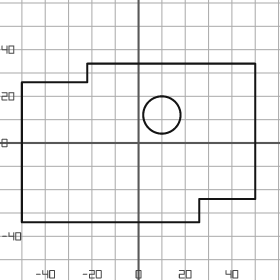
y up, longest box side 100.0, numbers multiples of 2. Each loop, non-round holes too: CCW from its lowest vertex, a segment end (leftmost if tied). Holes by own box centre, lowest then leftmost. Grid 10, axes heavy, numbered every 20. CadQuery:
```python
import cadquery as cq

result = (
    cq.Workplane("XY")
    .moveTo(-50.0, -34.0)
    .lineTo(26.0, -34.0)
    .lineTo(26.0, -24.0)
    .lineTo(50.0, -24.0)
    .lineTo(50.0, 34.0)
    .lineTo(-22.0, 34.0)
    .lineTo(-22.0, 26.0)
    .lineTo(-50.0, 26.0)
    .close()
    .moveTo(10.0, 12.0)
    .circle(8.0)
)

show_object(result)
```